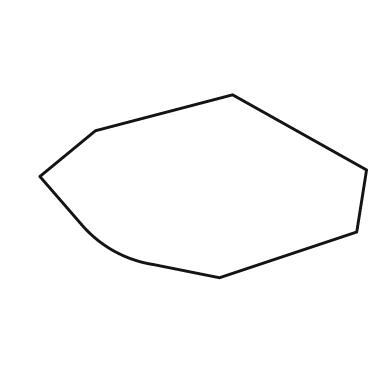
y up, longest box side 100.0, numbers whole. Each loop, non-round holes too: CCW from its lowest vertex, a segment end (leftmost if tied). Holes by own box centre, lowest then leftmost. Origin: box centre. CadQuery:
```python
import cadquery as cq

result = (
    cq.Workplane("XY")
    .moveTo(5.0, -28.0)
    .lineTo(47.0, -14.0)
    .lineTo(50.0, 5.0)
    .lineTo(9.0, 28.0)
    .lineTo(-33.0, 17.0)
    .lineTo(-50.0, 3.0)
    .lineTo(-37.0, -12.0)
    .threePointArc((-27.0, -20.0), (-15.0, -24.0))
    .close()
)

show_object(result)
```